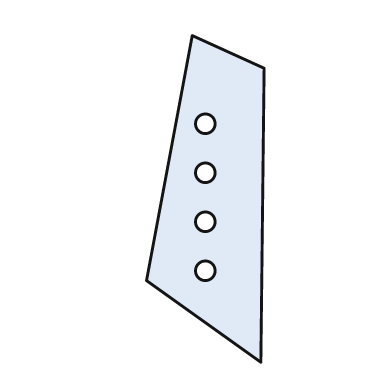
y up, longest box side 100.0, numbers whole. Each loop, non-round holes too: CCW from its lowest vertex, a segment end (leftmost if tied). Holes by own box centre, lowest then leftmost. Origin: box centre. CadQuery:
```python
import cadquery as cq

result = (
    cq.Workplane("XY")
    .moveTo(17.0, -50.0)
    .lineTo(18.0, 40.0)
    .lineTo(-4.0, 50.0)
    .lineTo(-18.0, -25.0)
    .close()
    .moveTo(0.0, -22.0)
    .circle(3.0)
    .moveTo(0.0, -7.0)
    .circle(3.0)
    .moveTo(0.0, 8.0)
    .circle(3.0)
    .moveTo(0.0, 23.0)
    .circle(3.0)
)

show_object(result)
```